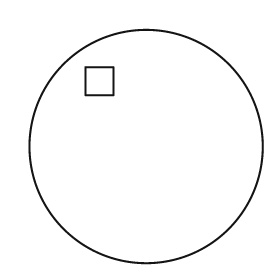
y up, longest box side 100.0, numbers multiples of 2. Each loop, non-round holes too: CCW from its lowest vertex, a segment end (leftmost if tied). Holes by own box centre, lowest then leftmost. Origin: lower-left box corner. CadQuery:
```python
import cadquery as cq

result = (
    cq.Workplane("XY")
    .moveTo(50.0, 50.0)
    .circle(50.0)
    .moveTo(24.0, 72.0)
    .lineTo(36.0, 72.0)
    .lineTo(36.0, 84.0)
    .lineTo(24.0, 84.0)
    .close()
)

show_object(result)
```